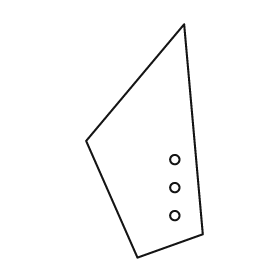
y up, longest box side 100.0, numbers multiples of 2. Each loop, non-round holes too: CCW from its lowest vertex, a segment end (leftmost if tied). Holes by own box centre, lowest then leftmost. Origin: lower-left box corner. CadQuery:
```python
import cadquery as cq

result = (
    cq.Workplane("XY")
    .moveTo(22.0, 0.0)
    .lineTo(50.0, 10.0)
    .lineTo(42.0, 100.0)
    .lineTo(0.0, 50.0)
    .close()
    .moveTo(38.0, 18.0)
    .circle(2.0)
    .moveTo(38.0, 30.0)
    .circle(2.0)
    .moveTo(38.0, 42.0)
    .circle(2.0)
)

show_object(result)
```